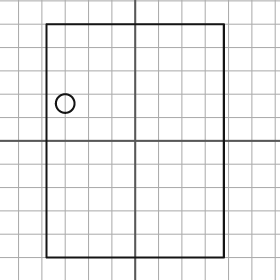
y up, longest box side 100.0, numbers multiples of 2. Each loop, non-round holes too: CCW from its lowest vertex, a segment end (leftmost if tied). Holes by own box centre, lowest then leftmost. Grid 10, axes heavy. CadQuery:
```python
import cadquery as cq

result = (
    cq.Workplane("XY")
    .moveTo(-38.0, -50.0)
    .lineTo(38.0, -50.0)
    .lineTo(38.0, 50.0)
    .lineTo(-38.0, 50.0)
    .close()
    .moveTo(-30.0, 16.0)
    .circle(4.0)
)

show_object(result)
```